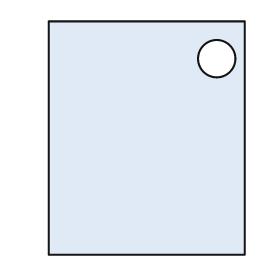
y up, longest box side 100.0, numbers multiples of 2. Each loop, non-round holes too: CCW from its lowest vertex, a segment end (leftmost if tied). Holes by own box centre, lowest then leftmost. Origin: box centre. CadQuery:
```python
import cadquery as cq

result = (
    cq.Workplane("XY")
    .moveTo(-42.0, -50.0)
    .lineTo(42.0, -50.0)
    .lineTo(42.0, 50.0)
    .lineTo(-42.0, 50.0)
    .close()
    .moveTo(30.0, 34.0)
    .circle(8.0)
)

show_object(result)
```